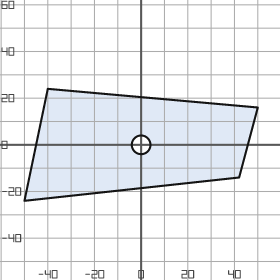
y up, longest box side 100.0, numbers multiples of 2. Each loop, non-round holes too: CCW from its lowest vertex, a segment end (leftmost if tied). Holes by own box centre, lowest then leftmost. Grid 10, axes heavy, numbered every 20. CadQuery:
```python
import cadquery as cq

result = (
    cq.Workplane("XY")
    .moveTo(-50.0, -24.0)
    .lineTo(42.0, -14.0)
    .lineTo(50.0, 16.0)
    .lineTo(-40.0, 24.0)
    .close()
    .moveTo(0.0, 0.0)
    .circle(4.0)
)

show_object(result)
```